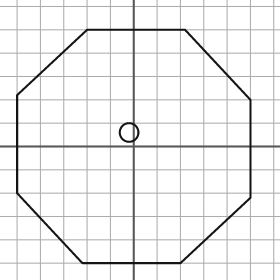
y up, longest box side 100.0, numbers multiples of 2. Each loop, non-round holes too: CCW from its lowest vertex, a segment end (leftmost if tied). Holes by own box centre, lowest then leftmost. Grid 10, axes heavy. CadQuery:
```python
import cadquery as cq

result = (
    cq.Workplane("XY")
    .moveTo(-22.0, -50.0)
    .lineTo(20.0, -50.0)
    .lineTo(50.0, -22.0)
    .lineTo(50.0, 20.0)
    .lineTo(22.0, 50.0)
    .lineTo(-20.0, 50.0)
    .lineTo(-50.0, 22.0)
    .lineTo(-50.0, -20.0)
    .close()
    .moveTo(-2.0, 6.0)
    .circle(4.0)
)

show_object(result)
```